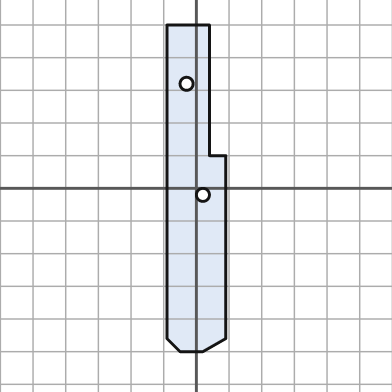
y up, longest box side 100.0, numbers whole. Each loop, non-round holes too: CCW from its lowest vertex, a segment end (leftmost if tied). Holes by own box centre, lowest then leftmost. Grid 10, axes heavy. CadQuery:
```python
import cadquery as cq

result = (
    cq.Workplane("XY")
    .moveTo(-5.0, -50.0)
    .lineTo(2.0, -50.0)
    .lineTo(9.0, -46.0)
    .lineTo(9.0, 10.0)
    .lineTo(4.0, 10.0)
    .lineTo(4.0, 50.0)
    .lineTo(-9.0, 50.0)
    .lineTo(-9.0, -46.0)
    .close()
    .moveTo(2.0, -2.0)
    .circle(2.0)
    .moveTo(-3.0, 32.0)
    .circle(2.0)
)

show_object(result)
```